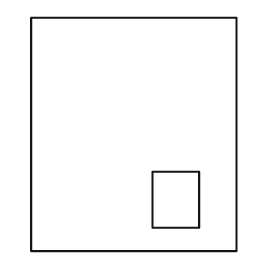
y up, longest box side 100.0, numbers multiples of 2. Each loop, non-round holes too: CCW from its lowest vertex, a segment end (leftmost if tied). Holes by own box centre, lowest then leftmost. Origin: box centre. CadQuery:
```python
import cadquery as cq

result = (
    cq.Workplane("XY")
    .moveTo(-44.0, -50.0)
    .lineTo(44.0, -50.0)
    .lineTo(44.0, 50.0)
    .lineTo(-44.0, 50.0)
    .close()
    .moveTo(8.0, -40.0)
    .lineTo(28.0, -40.0)
    .lineTo(28.0, -16.0)
    .lineTo(8.0, -16.0)
    .close()
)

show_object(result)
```